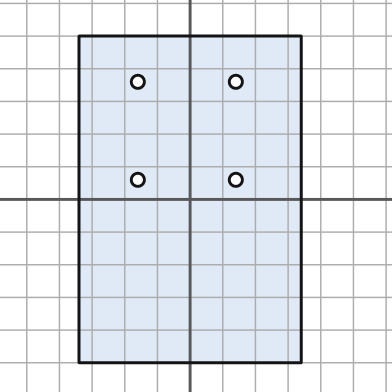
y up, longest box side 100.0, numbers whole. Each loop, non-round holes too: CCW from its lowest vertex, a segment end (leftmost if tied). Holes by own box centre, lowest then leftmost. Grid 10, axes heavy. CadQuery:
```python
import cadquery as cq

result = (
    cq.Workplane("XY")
    .moveTo(-34.0, -50.0)
    .lineTo(34.0, -50.0)
    .lineTo(34.0, 50.0)
    .lineTo(-34.0, 50.0)
    .close()
    .moveTo(-16.0, 6.0)
    .circle(2.0)
    .moveTo(14.0, 6.0)
    .circle(2.0)
    .moveTo(-16.0, 36.0)
    .circle(2.0)
    .moveTo(14.0, 36.0)
    .circle(2.0)
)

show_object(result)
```